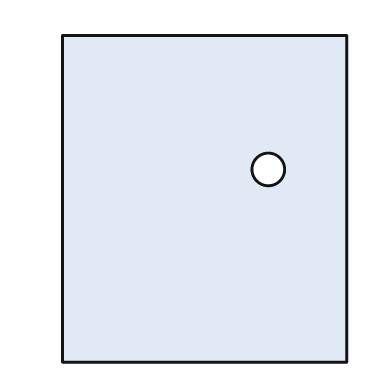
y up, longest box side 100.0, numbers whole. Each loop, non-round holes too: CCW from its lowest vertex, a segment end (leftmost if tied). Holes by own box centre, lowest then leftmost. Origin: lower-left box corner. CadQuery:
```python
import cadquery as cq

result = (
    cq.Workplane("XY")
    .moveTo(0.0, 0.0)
    .lineTo(87.0, 0.0)
    .lineTo(87.0, 100.0)
    .lineTo(0.0, 100.0)
    .close()
    .moveTo(63.0, 59.0)
    .circle(5.0)
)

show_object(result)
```